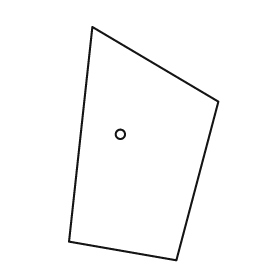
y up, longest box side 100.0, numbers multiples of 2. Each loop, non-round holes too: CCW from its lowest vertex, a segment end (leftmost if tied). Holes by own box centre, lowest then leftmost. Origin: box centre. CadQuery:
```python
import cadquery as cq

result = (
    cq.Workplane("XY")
    .moveTo(14.0, -50.0)
    .lineTo(32.0, 18.0)
    .lineTo(-22.0, 50.0)
    .lineTo(-32.0, -42.0)
    .close()
    .moveTo(-10.0, 4.0)
    .circle(2.0)
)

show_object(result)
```